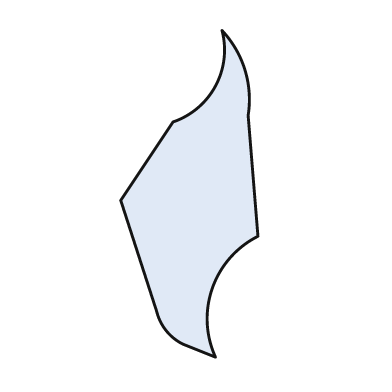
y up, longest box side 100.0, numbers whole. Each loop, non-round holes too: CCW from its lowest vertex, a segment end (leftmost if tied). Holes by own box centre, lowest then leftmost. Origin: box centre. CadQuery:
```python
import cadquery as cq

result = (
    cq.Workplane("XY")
    .moveTo(8.0, -50.0)
    .threePointArc((7.0, -29.0), (21.0, -13.0))
    .lineTo(18.0, 24.0)
    .threePointArc((17.0, 38.0), (10.0, 50.0))
    .threePointArc((8.0, 33.0), (-5.0, 22.0))
    .lineTo(-21.0, -2.0)
    .lineTo(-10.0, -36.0)
    .threePointArc((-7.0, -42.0), (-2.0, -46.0))
    .close()
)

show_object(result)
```